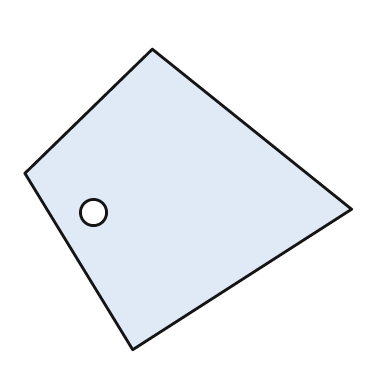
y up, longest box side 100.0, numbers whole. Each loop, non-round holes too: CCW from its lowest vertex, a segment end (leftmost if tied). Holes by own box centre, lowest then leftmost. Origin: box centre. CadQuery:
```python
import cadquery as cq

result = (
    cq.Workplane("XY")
    .moveTo(-17.0, -46.0)
    .lineTo(50.0, -3.0)
    .lineTo(-11.0, 46.0)
    .lineTo(-50.0, 8.0)
    .close()
    .moveTo(-29.0, -4.0)
    .circle(4.0)
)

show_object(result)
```